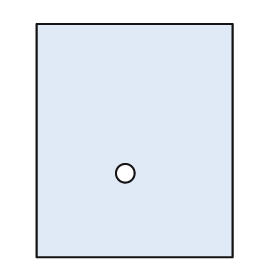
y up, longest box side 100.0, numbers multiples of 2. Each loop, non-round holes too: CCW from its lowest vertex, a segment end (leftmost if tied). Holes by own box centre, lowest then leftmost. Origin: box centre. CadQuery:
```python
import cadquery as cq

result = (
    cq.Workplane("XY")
    .moveTo(-42.0, -50.0)
    .lineTo(42.0, -50.0)
    .lineTo(42.0, 50.0)
    .lineTo(-42.0, 50.0)
    .close()
    .moveTo(-4.0, -14.0)
    .circle(4.0)
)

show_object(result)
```